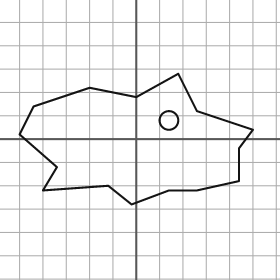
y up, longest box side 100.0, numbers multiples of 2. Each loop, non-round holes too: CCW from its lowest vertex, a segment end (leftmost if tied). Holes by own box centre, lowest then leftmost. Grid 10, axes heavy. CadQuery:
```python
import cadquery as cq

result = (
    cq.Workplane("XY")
    .moveTo(-2.0, -28.0)
    .lineTo(14.0, -22.0)
    .lineTo(26.0, -22.0)
    .lineTo(44.0, -18.0)
    .lineTo(44.0, -4.0)
    .lineTo(50.0, 4.0)
    .lineTo(26.0, 12.0)
    .lineTo(18.0, 28.0)
    .lineTo(0.0, 18.0)
    .lineTo(-20.0, 22.0)
    .lineTo(-44.0, 14.0)
    .lineTo(-50.0, 2.0)
    .lineTo(-34.0, -12.0)
    .lineTo(-40.0, -22.0)
    .lineTo(-12.0, -20.0)
    .close()
    .moveTo(14.0, 8.0)
    .circle(4.0)
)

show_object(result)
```